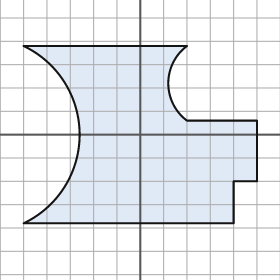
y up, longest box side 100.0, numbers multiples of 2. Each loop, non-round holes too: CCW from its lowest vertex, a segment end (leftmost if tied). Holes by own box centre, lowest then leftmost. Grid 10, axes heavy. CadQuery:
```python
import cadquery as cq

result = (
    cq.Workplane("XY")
    .moveTo(-50.0, -38.0)
    .lineTo(40.0, -38.0)
    .lineTo(40.0, -20.0)
    .lineTo(50.0, -20.0)
    .lineTo(50.0, 6.0)
    .lineTo(20.0, 6.0)
    .threePointArc((12.0, 22.0), (20.0, 38.0))
    .lineTo(-50.0, 38.0)
    .threePointArc((-26.0, 0.0), (-50.0, -38.0))
    .close()
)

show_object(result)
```